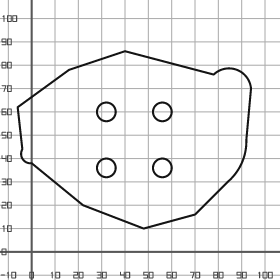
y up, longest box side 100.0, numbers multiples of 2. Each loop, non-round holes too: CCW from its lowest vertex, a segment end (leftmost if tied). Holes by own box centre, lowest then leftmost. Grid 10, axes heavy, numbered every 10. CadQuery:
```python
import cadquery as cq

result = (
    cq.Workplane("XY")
    .moveTo(48.0, 10.0)
    .lineTo(70.0, 16.0)
    .lineTo(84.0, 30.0)
    .threePointArc((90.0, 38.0), (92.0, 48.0))
    .lineTo(94.0, 70.0)
    .threePointArc((88.0, 78.0), (78.0, 76.0))
    .lineTo(40.0, 86.0)
    .lineTo(16.0, 78.0)
    .lineTo(-6.0, 62.0)
    .lineTo(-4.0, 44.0)
    .threePointArc((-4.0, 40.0), (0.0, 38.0))
    .lineTo(22.0, 20.0)
    .close()
    .moveTo(32.0, 36.0)
    .circle(4.0)
    .moveTo(56.0, 36.0)
    .circle(4.0)
    .moveTo(32.0, 60.0)
    .circle(4.0)
    .moveTo(56.0, 60.0)
    .circle(4.0)
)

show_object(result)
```